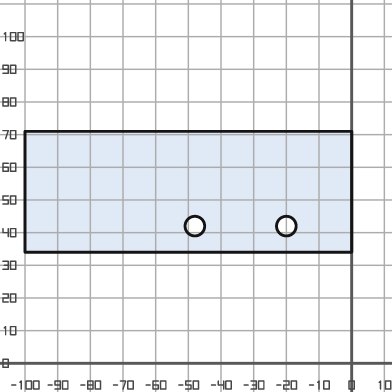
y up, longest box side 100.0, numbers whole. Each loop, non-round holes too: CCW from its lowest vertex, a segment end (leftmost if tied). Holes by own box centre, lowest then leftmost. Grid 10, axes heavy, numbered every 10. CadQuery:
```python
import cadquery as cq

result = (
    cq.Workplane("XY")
    .moveTo(-100.0, 34.0)
    .lineTo(0.0, 34.0)
    .lineTo(0.0, 71.0)
    .lineTo(-100.0, 71.0)
    .close()
    .moveTo(-48.0, 42.0)
    .circle(3.0)
    .moveTo(-20.0, 42.0)
    .circle(3.0)
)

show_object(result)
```